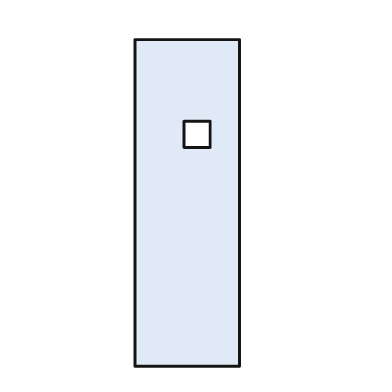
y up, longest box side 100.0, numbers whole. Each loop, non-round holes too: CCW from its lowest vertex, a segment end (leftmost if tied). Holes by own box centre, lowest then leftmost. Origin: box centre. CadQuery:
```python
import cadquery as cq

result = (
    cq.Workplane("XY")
    .moveTo(-16.0, -50.0)
    .lineTo(16.0, -50.0)
    .lineTo(16.0, 50.0)
    .lineTo(-16.0, 50.0)
    .close()
    .moveTo(-1.0, 17.0)
    .lineTo(7.0, 17.0)
    .lineTo(7.0, 25.0)
    .lineTo(-1.0, 25.0)
    .close()
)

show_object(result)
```